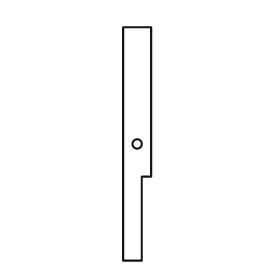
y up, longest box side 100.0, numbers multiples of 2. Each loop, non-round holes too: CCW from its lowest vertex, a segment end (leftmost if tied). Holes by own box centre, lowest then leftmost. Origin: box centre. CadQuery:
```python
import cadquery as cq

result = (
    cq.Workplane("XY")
    .moveTo(-6.0, -50.0)
    .lineTo(2.0, -50.0)
    .lineTo(2.0, -14.0)
    .lineTo(6.0, -14.0)
    .lineTo(6.0, 50.0)
    .lineTo(-6.0, 50.0)
    .close()
    .moveTo(0.0, 0.0)
    .circle(2.0)
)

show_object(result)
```